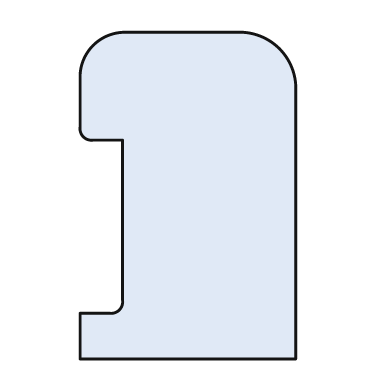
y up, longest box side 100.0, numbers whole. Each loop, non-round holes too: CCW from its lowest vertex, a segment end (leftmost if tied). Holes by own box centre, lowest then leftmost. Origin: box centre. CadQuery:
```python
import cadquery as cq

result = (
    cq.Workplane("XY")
    .moveTo(-33.0, -50.0)
    .lineTo(33.0, -50.0)
    .lineTo(33.0, 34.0)
    .threePointArc((28.0, 45.0), (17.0, 50.0))
    .lineTo(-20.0, 50.0)
    .threePointArc((-29.0, 46.0), (-33.0, 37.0))
    .lineTo(-33.0, 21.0)
    .threePointArc((-32.0, 18.0), (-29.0, 17.0))
    .lineTo(-20.0, 17.0)
    .lineTo(-20.0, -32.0)
    .threePointArc((-21.0, -35.0), (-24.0, -36.0))
    .lineTo(-33.0, -36.0)
    .close()
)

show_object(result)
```